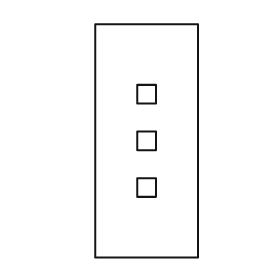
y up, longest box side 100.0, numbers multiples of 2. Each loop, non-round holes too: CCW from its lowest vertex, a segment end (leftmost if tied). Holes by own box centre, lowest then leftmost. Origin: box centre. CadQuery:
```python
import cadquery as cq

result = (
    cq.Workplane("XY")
    .moveTo(-22.0, -50.0)
    .lineTo(22.0, -50.0)
    .lineTo(22.0, 50.0)
    .lineTo(-22.0, 50.0)
    .close()
    .moveTo(-4.0, -24.0)
    .lineTo(4.0, -24.0)
    .lineTo(4.0, -16.0)
    .lineTo(-4.0, -16.0)
    .close()
    .moveTo(-4.0, -4.0)
    .lineTo(4.0, -4.0)
    .lineTo(4.0, 4.0)
    .lineTo(-4.0, 4.0)
    .close()
    .moveTo(-4.0, 16.0)
    .lineTo(4.0, 16.0)
    .lineTo(4.0, 24.0)
    .lineTo(-4.0, 24.0)
    .close()
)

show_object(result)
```